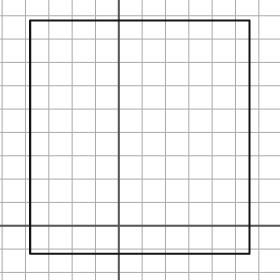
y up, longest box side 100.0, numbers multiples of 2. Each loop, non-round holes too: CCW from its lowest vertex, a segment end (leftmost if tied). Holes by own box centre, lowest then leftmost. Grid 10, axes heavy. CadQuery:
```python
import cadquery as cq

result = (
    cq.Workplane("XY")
    .moveTo(-38.0, -12.0)
    .lineTo(56.0, -12.0)
    .lineTo(56.0, 88.0)
    .lineTo(-38.0, 88.0)
    .close()
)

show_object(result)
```